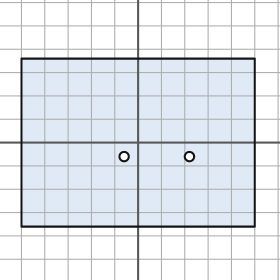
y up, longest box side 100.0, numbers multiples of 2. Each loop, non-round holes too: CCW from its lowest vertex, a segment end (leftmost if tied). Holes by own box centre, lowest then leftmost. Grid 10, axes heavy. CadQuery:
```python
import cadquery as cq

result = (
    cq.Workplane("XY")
    .moveTo(-50.0, -36.0)
    .lineTo(50.0, -36.0)
    .lineTo(50.0, 36.0)
    .lineTo(-50.0, 36.0)
    .close()
    .moveTo(-6.0, -6.0)
    .circle(2.0)
    .moveTo(22.0, -6.0)
    .circle(2.0)
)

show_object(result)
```